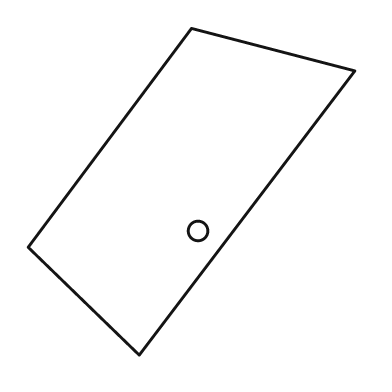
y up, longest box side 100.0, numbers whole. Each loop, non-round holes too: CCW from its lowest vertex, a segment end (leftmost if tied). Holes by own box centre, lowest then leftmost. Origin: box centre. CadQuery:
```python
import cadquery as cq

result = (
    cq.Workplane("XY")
    .moveTo(-16.0, -50.0)
    .lineTo(50.0, 37.0)
    .lineTo(0.0, 50.0)
    .lineTo(-50.0, -17.0)
    .close()
    .moveTo(2.0, -12.0)
    .circle(3.0)
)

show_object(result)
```